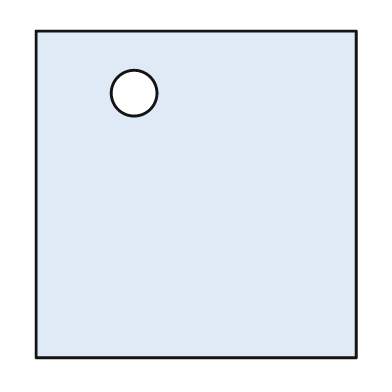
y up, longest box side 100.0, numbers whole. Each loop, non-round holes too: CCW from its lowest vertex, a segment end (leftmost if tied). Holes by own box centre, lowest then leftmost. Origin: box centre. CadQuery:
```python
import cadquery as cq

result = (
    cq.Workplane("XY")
    .moveTo(-49.0, -50.0)
    .lineTo(49.0, -50.0)
    .lineTo(49.0, 50.0)
    .lineTo(-49.0, 50.0)
    .close()
    .moveTo(-19.0, 31.0)
    .circle(7.0)
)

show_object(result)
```